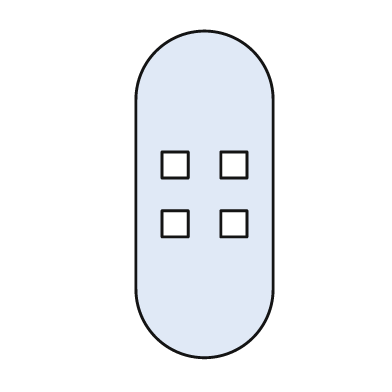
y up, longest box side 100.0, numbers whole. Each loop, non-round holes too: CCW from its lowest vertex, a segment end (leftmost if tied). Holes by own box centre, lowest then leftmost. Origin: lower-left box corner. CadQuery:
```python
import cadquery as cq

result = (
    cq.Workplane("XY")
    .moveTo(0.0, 21.0)
    .threePointArc((21.0, 0.0), (42.0, 21.0))
    .lineTo(42.0, 79.0)
    .threePointArc((21.0, 100.0), (0.0, 79.0))
    .close()
    .moveTo(8.0, 37.0)
    .lineTo(16.0, 37.0)
    .lineTo(16.0, 45.0)
    .lineTo(8.0, 45.0)
    .close()
    .moveTo(26.0, 37.0)
    .lineTo(34.0, 37.0)
    .lineTo(34.0, 45.0)
    .lineTo(26.0, 45.0)
    .close()
    .moveTo(8.0, 55.0)
    .lineTo(16.0, 55.0)
    .lineTo(16.0, 63.0)
    .lineTo(8.0, 63.0)
    .close()
    .moveTo(26.0, 55.0)
    .lineTo(34.0, 55.0)
    .lineTo(34.0, 63.0)
    .lineTo(26.0, 63.0)
    .close()
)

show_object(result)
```